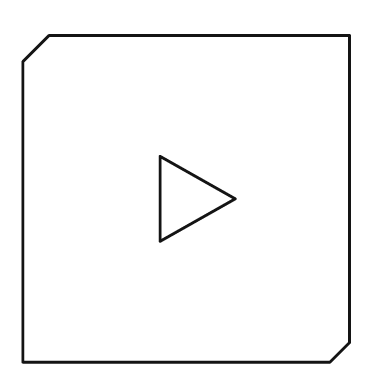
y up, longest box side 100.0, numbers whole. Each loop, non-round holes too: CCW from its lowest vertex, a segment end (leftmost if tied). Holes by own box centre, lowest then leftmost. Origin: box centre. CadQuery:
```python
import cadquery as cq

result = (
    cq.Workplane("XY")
    .moveTo(-50.0, -50.0)
    .lineTo(44.0, -50.0)
    .lineTo(50.0, -44.0)
    .lineTo(50.0, 50.0)
    .lineTo(-42.0, 50.0)
    .lineTo(-50.0, 42.0)
    .close()
    .moveTo(-8.0, -13.0)
    .lineTo(15.0, 0.0)
    .lineTo(-8.0, 13.0)
    .close()
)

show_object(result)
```